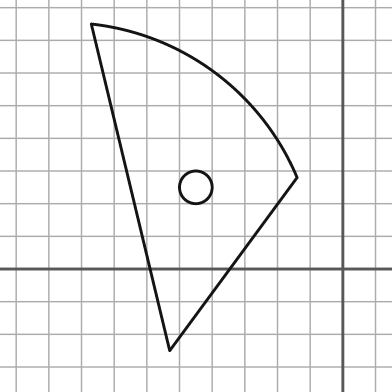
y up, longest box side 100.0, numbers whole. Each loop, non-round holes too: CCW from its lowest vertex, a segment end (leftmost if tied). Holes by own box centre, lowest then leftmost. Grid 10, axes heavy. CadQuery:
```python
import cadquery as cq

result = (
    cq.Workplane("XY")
    .moveTo(-53.0, -25.0)
    .lineTo(-14.0, 28.0)
    .threePointArc((-39.0, 60.0), (-77.0, 75.0))
    .close()
    .moveTo(-45.0, 25.0)
    .circle(5.0)
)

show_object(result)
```